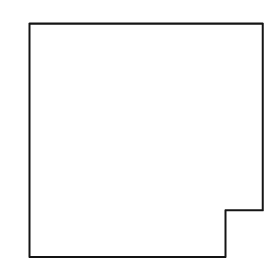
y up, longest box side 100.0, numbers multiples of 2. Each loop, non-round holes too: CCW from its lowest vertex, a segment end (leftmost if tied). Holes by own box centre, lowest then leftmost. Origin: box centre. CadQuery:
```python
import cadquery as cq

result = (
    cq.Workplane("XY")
    .moveTo(-50.0, -50.0)
    .lineTo(34.0, -50.0)
    .lineTo(34.0, -30.0)
    .lineTo(50.0, -30.0)
    .lineTo(50.0, 50.0)
    .lineTo(-50.0, 50.0)
    .close()
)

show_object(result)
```